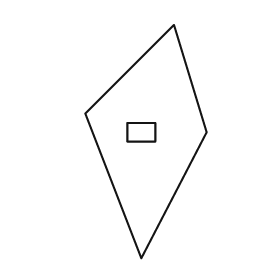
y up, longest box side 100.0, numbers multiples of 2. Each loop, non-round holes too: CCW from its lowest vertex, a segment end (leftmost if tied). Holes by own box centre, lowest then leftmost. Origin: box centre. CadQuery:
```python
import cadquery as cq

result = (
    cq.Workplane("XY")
    .moveTo(-2.0, -50.0)
    .lineTo(26.0, 4.0)
    .lineTo(12.0, 50.0)
    .lineTo(-26.0, 12.0)
    .close()
    .moveTo(-8.0, 0.0)
    .lineTo(4.0, 0.0)
    .lineTo(4.0, 8.0)
    .lineTo(-8.0, 8.0)
    .close()
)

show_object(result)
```